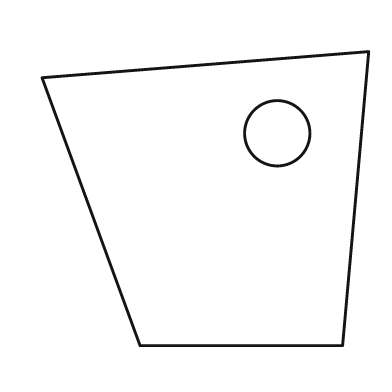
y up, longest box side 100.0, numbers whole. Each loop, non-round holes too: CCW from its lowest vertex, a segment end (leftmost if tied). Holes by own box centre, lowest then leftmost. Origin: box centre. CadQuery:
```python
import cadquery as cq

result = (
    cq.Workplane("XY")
    .moveTo(-20.0, -45.0)
    .lineTo(42.0, -45.0)
    .lineTo(50.0, 45.0)
    .lineTo(-50.0, 37.0)
    .close()
    .moveTo(22.0, 20.0)
    .circle(10.0)
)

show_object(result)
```